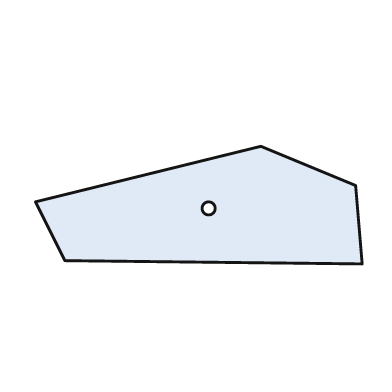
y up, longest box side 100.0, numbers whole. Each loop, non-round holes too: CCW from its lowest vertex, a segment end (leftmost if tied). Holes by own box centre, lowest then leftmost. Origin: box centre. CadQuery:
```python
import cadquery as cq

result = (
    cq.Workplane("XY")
    .moveTo(50.0, -18.0)
    .lineTo(48.0, 6.0)
    .lineTo(19.0, 18.0)
    .lineTo(-50.0, 1.0)
    .lineTo(-41.0, -17.0)
    .close()
    .moveTo(3.0, -1.0)
    .circle(2.0)
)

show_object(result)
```